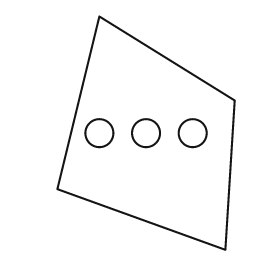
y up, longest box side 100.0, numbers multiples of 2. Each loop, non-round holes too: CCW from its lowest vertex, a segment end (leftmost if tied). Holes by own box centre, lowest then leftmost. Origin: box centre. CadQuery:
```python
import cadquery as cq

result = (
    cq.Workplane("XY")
    .moveTo(34.0, -50.0)
    .lineTo(38.0, 14.0)
    .lineTo(-20.0, 50.0)
    .lineTo(-38.0, -24.0)
    .close()
    .moveTo(-20.0, 0.0)
    .circle(6.0)
    .moveTo(0.0, 0.0)
    .circle(6.0)
    .moveTo(20.0, 0.0)
    .circle(6.0)
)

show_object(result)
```